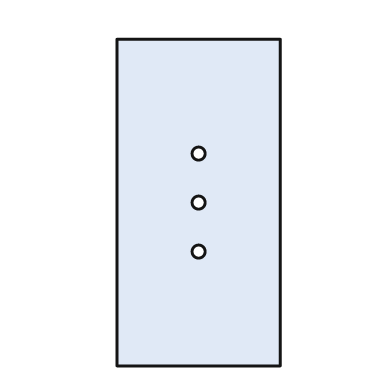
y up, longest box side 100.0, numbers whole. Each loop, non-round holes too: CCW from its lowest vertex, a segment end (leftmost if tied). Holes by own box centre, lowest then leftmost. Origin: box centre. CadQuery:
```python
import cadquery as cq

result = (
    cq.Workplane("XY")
    .moveTo(-25.0, -50.0)
    .lineTo(25.0, -50.0)
    .lineTo(25.0, 50.0)
    .lineTo(-25.0, 50.0)
    .close()
    .moveTo(0.0, -15.0)
    .circle(2.0)
    .moveTo(0.0, 0.0)
    .circle(2.0)
    .moveTo(0.0, 15.0)
    .circle(2.0)
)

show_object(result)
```